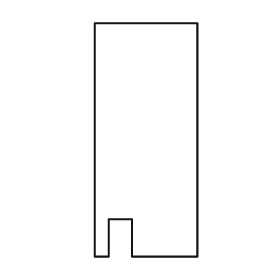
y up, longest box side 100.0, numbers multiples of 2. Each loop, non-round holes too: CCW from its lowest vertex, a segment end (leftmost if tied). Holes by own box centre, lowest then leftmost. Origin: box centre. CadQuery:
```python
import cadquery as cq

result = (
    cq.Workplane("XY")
    .moveTo(-22.0, -50.0)
    .lineTo(-16.0, -50.0)
    .lineTo(-16.0, -34.0)
    .lineTo(-6.0, -34.0)
    .lineTo(-6.0, -50.0)
    .lineTo(22.0, -50.0)
    .lineTo(22.0, 50.0)
    .lineTo(-22.0, 50.0)
    .close()
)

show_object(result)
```